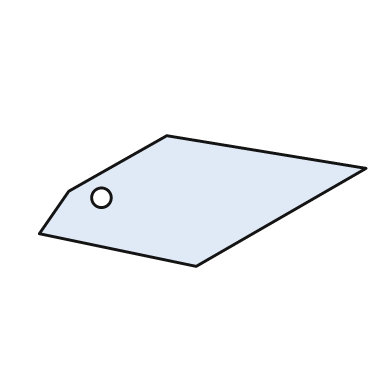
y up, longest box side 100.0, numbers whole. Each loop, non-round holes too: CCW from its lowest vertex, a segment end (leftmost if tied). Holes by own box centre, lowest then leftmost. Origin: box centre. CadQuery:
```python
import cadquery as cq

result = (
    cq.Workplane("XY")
    .moveTo(-2.0, -20.0)
    .lineTo(50.0, 10.0)
    .lineTo(-11.0, 20.0)
    .lineTo(-41.0, 3.0)
    .lineTo(-50.0, -10.0)
    .close()
    .moveTo(-31.0, 1.0)
    .circle(3.0)
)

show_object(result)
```